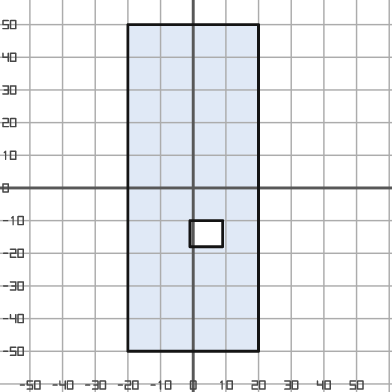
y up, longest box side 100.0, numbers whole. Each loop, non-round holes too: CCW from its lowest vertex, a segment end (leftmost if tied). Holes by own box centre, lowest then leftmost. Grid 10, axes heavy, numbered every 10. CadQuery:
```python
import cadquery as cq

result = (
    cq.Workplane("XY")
    .moveTo(-20.0, -50.0)
    .lineTo(20.0, -50.0)
    .lineTo(20.0, 50.0)
    .lineTo(-20.0, 50.0)
    .close()
    .moveTo(-1.0, -18.0)
    .lineTo(9.0, -18.0)
    .lineTo(9.0, -10.0)
    .lineTo(-1.0, -10.0)
    .close()
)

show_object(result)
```